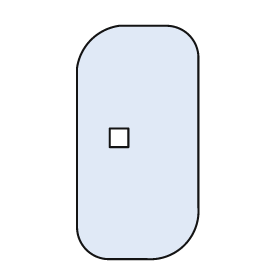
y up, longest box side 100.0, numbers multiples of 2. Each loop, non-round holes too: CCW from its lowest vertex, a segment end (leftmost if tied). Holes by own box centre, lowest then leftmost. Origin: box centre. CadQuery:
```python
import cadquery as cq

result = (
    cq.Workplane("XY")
    .moveTo(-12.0, -50.0)
    .lineTo(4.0, -50.0)
    .threePointArc((20.0, -44.0), (26.0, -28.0))
    .lineTo(26.0, 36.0)
    .threePointArc((22.0, 46.0), (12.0, 50.0))
    .lineTo(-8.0, 50.0)
    .threePointArc((-20.0, 44.0), (-26.0, 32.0))
    .lineTo(-26.0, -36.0)
    .threePointArc((-22.0, -46.0), (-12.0, -50.0))
    .close()
    .moveTo(-12.0, -2.0)
    .lineTo(-4.0, -2.0)
    .lineTo(-4.0, 6.0)
    .lineTo(-12.0, 6.0)
    .close()
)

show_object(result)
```